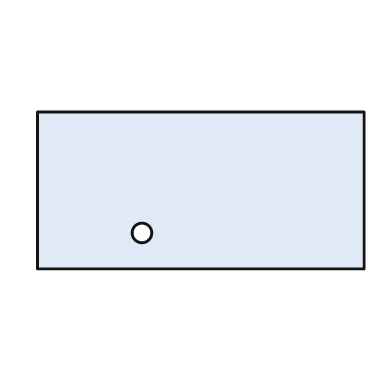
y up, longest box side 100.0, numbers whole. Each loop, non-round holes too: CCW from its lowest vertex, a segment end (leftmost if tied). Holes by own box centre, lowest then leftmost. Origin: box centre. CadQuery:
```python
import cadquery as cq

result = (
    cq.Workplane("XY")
    .moveTo(-50.0, -24.0)
    .lineTo(50.0, -24.0)
    .lineTo(50.0, 24.0)
    .lineTo(-50.0, 24.0)
    .close()
    .moveTo(-18.0, -13.0)
    .circle(3.0)
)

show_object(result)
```